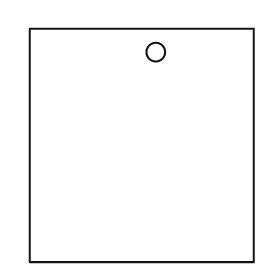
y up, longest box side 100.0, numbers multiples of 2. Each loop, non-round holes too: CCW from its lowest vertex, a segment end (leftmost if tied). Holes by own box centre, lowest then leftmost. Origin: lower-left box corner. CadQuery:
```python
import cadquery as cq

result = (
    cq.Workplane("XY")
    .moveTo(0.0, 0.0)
    .lineTo(96.0, 0.0)
    .lineTo(96.0, 100.0)
    .lineTo(0.0, 100.0)
    .close()
    .moveTo(54.0, 90.0)
    .circle(4.0)
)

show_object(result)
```